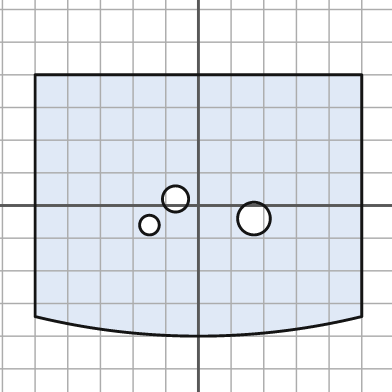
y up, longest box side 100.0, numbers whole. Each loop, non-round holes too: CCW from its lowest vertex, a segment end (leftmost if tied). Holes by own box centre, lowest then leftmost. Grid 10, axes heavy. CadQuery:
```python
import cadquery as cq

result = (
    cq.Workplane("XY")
    .moveTo(-50.0, -34.0)
    .threePointArc((0.0, -40.0), (50.0, -34.0))
    .lineTo(50.0, 40.0)
    .lineTo(-50.0, 40.0)
    .close()
    .moveTo(-15.0, -6.0)
    .circle(3.0)
    .moveTo(17.0, -4.0)
    .circle(5.0)
    .moveTo(-7.0, 2.0)
    .circle(4.0)
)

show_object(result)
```